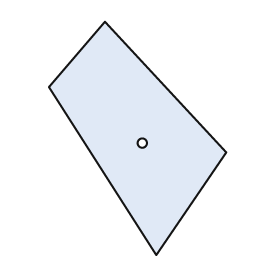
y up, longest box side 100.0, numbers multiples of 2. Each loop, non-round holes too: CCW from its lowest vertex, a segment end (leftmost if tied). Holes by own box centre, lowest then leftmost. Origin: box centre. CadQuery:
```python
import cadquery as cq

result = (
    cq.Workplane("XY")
    .moveTo(8.0, -50.0)
    .lineTo(38.0, -6.0)
    .lineTo(-14.0, 50.0)
    .lineTo(-38.0, 22.0)
    .close()
    .moveTo(2.0, -2.0)
    .circle(2.0)
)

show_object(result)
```